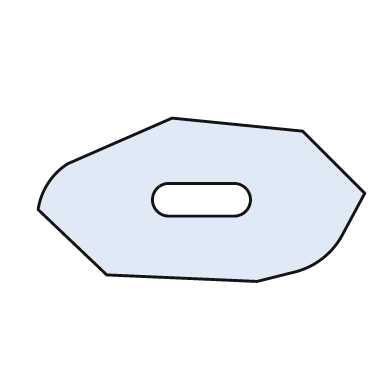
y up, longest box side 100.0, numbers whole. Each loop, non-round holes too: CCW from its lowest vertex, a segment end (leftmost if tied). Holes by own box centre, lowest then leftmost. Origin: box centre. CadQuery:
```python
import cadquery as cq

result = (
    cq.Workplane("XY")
    .moveTo(17.0, -25.0)
    .lineTo(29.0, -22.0)
    .threePointArc((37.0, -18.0), (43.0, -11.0))
    .lineTo(50.0, 2.0)
    .lineTo(31.0, 21.0)
    .lineTo(-9.0, 25.0)
    .lineTo(-41.0, 11.0)
    .threePointArc((-47.0, 5.0), (-50.0, -3.0))
    .lineTo(-29.0, -23.0)
    .close()
    .moveTo(-10.0, -5.0)
    .lineTo(10.0, -5.0)
    .threePointArc((15.0, 0.0), (10.0, 5.0))
    .lineTo(-10.0, 5.0)
    .threePointArc((-15.0, 0.0), (-10.0, -5.0))
    .close()
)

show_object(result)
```